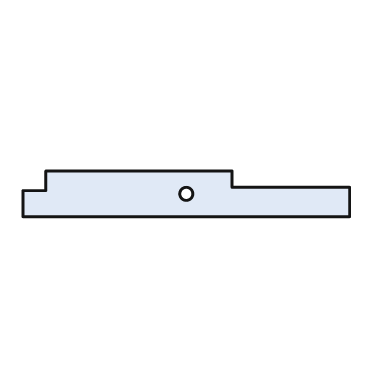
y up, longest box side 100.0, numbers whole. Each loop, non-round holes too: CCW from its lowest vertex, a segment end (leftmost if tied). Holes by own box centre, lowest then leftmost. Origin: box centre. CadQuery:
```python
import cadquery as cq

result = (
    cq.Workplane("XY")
    .moveTo(-50.0, -7.0)
    .lineTo(50.0, -7.0)
    .lineTo(50.0, 2.0)
    .lineTo(14.0, 2.0)
    .lineTo(14.0, 7.0)
    .lineTo(-43.0, 7.0)
    .lineTo(-43.0, 1.0)
    .lineTo(-50.0, 1.0)
    .close()
    .moveTo(0.0, 0.0)
    .circle(2.0)
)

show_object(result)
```